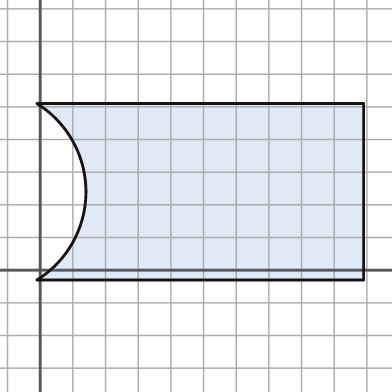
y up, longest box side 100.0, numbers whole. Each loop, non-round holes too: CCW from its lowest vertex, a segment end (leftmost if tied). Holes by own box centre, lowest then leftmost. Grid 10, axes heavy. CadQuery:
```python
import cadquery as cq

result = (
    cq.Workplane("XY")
    .moveTo(-1.0, -3.0)
    .lineTo(99.0, -3.0)
    .lineTo(99.0, 51.0)
    .lineTo(-1.0, 51.0)
    .threePointArc((14.0, 24.0), (-1.0, -3.0))
    .close()
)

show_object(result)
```